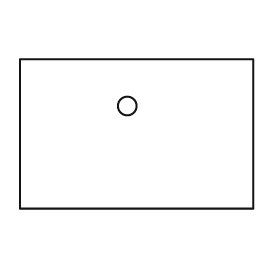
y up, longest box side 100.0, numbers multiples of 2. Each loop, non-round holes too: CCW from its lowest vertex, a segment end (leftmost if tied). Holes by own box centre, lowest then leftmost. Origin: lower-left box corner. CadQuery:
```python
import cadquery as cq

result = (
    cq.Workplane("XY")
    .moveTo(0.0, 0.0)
    .lineTo(100.0, 0.0)
    .lineTo(100.0, 64.0)
    .lineTo(0.0, 64.0)
    .close()
    .moveTo(46.0, 44.0)
    .circle(4.0)
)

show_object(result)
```